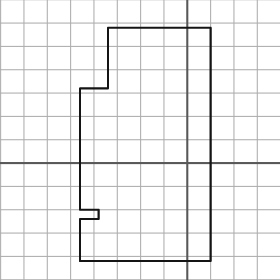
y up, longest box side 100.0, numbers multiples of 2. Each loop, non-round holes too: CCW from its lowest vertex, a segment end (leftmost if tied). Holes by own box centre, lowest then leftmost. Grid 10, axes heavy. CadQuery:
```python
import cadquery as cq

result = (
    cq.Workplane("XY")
    .moveTo(-46.0, -42.0)
    .lineTo(10.0, -42.0)
    .lineTo(10.0, 58.0)
    .lineTo(-34.0, 58.0)
    .lineTo(-34.0, 32.0)
    .lineTo(-46.0, 32.0)
    .lineTo(-46.0, -20.0)
    .lineTo(-38.0, -20.0)
    .lineTo(-38.0, -24.0)
    .lineTo(-46.0, -24.0)
    .close()
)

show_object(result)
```